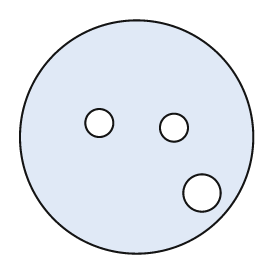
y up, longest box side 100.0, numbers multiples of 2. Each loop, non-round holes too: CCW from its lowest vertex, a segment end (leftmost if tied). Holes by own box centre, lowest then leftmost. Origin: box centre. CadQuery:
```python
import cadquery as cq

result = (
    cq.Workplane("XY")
    .moveTo(0.0, 0.0)
    .circle(50.0)
    .moveTo(28.0, -24.0)
    .circle(8.0)
    .moveTo(16.0, 4.0)
    .circle(6.0)
    .moveTo(-16.0, 6.0)
    .circle(6.0)
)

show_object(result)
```